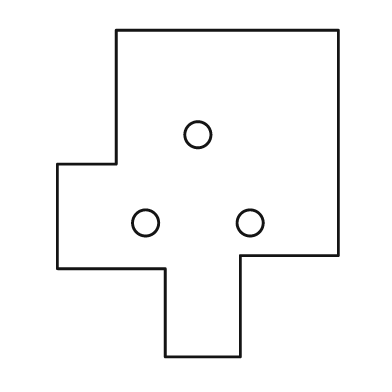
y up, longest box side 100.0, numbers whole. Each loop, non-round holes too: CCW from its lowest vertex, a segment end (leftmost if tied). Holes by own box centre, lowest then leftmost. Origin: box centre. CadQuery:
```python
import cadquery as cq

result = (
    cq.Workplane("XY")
    .moveTo(-10.0, -50.0)
    .lineTo(13.0, -50.0)
    .lineTo(13.0, -19.0)
    .lineTo(43.0, -19.0)
    .lineTo(43.0, 50.0)
    .lineTo(-25.0, 50.0)
    .lineTo(-25.0, 9.0)
    .lineTo(-43.0, 9.0)
    .lineTo(-43.0, -23.0)
    .lineTo(-10.0, -23.0)
    .close()
    .moveTo(-16.0, -9.0)
    .circle(4.0)
    .moveTo(16.0, -9.0)
    .circle(4.0)
    .moveTo(0.0, 18.0)
    .circle(4.0)
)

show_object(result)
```